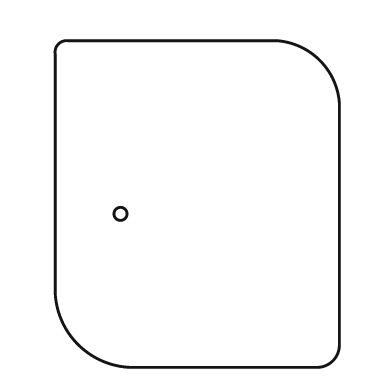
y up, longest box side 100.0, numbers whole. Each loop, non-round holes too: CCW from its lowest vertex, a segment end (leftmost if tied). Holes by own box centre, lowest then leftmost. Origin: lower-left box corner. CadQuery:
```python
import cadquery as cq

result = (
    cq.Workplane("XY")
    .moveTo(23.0, 0.0)
    .lineTo(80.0, 0.0)
    .threePointArc((85.0, 2.0), (87.0, 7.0))
    .lineTo(87.0, 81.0)
    .threePointArc((81.0, 94.0), (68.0, 100.0))
    .lineTo(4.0, 100.0)
    .threePointArc((1.0, 99.0), (0.0, 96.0))
    .lineTo(0.0, 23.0)
    .threePointArc((7.0, 7.0), (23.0, 0.0))
    .close()
    .moveTo(20.0, 47.0)
    .circle(2.0)
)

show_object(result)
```